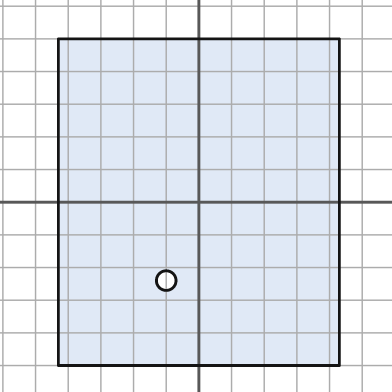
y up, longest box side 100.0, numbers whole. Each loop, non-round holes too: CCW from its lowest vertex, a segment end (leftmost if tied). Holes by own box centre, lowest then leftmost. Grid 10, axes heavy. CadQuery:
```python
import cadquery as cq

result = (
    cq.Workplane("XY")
    .moveTo(-43.0, -50.0)
    .lineTo(43.0, -50.0)
    .lineTo(43.0, 50.0)
    .lineTo(-43.0, 50.0)
    .close()
    .moveTo(-10.0, -24.0)
    .circle(3.0)
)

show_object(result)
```